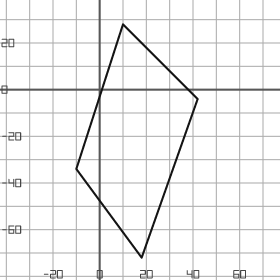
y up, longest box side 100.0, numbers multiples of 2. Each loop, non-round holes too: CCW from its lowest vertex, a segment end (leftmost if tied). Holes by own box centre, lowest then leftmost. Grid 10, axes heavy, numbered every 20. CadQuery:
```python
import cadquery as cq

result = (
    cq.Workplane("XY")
    .moveTo(18.0, -72.0)
    .lineTo(42.0, -4.0)
    .lineTo(10.0, 28.0)
    .lineTo(-10.0, -34.0)
    .close()
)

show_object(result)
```